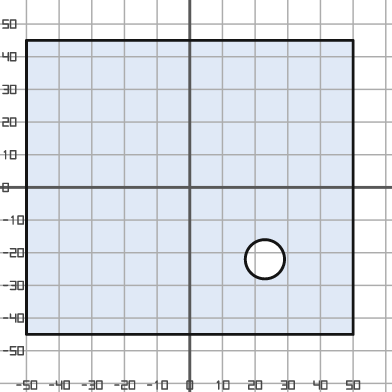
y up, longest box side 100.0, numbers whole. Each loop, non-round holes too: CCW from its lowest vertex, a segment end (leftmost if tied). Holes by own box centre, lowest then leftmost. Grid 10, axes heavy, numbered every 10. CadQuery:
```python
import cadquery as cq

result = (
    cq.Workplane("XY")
    .moveTo(-50.0, -45.0)
    .lineTo(50.0, -45.0)
    .lineTo(50.0, 45.0)
    .lineTo(-50.0, 45.0)
    .close()
    .moveTo(23.0, -22.0)
    .circle(6.0)
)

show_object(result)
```